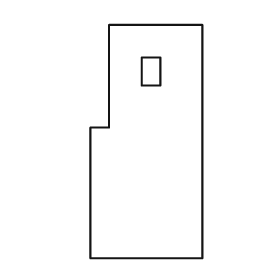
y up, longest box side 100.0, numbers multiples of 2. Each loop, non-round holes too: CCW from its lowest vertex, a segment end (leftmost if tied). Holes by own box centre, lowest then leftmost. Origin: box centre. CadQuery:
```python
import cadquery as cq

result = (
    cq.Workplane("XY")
    .moveTo(-24.0, -50.0)
    .lineTo(24.0, -50.0)
    .lineTo(24.0, 50.0)
    .lineTo(-16.0, 50.0)
    .lineTo(-16.0, 6.0)
    .lineTo(-24.0, 6.0)
    .close()
    .moveTo(-2.0, 24.0)
    .lineTo(6.0, 24.0)
    .lineTo(6.0, 36.0)
    .lineTo(-2.0, 36.0)
    .close()
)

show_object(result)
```